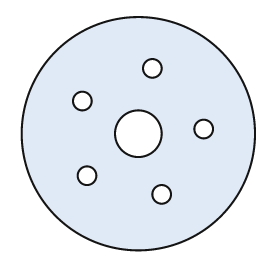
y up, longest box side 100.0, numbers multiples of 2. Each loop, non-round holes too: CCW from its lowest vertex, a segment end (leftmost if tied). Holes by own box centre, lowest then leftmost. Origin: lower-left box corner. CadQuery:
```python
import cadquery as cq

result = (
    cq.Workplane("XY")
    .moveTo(50.0, 50.0)
    .circle(50.0)
    .moveTo(60.0, 24.0)
    .circle(4.0)
    .moveTo(28.0, 32.0)
    .circle(4.0)
    .moveTo(50.0, 50.0)
    .circle(10.0)
    .moveTo(78.0, 52.0)
    .circle(4.0)
    .moveTo(26.0, 64.0)
    .circle(4.0)
    .moveTo(56.0, 78.0)
    .circle(4.0)
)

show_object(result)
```